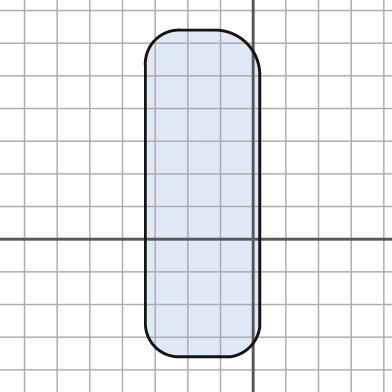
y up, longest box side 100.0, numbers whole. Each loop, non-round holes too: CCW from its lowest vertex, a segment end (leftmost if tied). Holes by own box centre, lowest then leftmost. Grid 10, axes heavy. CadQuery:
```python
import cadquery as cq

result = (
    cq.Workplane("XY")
    .moveTo(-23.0, -36.0)
    .lineTo(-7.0, -36.0)
    .threePointArc((-1.0, -33.0), (2.0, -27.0))
    .lineTo(2.0, 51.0)
    .threePointArc((-2.0, 60.0), (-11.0, 64.0))
    .lineTo(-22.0, 64.0)
    .threePointArc((-30.0, 61.0), (-33.0, 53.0))
    .lineTo(-33.0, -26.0)
    .threePointArc((-30.0, -33.0), (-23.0, -36.0))
    .close()
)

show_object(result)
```